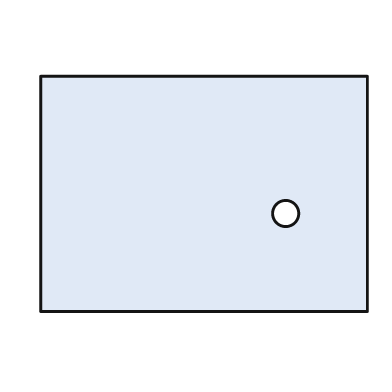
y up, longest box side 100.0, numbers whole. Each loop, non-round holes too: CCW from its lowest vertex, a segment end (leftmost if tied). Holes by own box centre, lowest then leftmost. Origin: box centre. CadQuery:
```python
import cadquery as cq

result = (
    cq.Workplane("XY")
    .moveTo(-50.0, -36.0)
    .lineTo(50.0, -36.0)
    .lineTo(50.0, 36.0)
    .lineTo(-50.0, 36.0)
    .close()
    .moveTo(25.0, -6.0)
    .circle(4.0)
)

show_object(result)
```